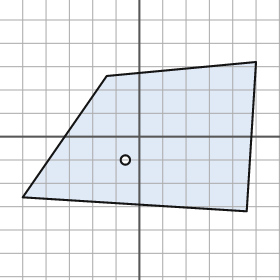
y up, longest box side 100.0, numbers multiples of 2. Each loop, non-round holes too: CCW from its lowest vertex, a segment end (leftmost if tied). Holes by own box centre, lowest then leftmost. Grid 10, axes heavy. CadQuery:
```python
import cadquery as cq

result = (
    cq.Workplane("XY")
    .moveTo(46.0, -32.0)
    .lineTo(50.0, 32.0)
    .lineTo(-14.0, 26.0)
    .lineTo(-50.0, -26.0)
    .close()
    .moveTo(-6.0, -10.0)
    .circle(2.0)
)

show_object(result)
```